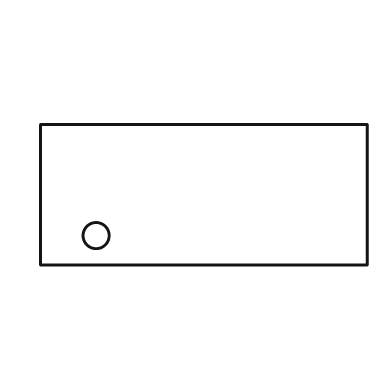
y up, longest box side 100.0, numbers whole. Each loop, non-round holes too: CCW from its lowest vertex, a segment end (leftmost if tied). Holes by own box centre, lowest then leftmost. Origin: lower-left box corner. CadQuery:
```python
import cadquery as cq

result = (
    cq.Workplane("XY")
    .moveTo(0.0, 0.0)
    .lineTo(100.0, 0.0)
    .lineTo(100.0, 43.0)
    .lineTo(0.0, 43.0)
    .close()
    .moveTo(17.0, 9.0)
    .circle(4.0)
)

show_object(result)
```